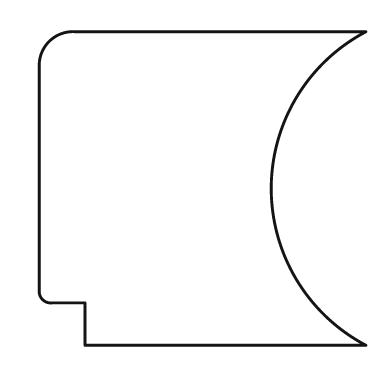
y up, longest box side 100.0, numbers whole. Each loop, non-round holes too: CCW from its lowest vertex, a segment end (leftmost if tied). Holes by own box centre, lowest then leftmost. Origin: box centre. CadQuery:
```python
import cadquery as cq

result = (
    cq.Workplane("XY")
    .moveTo(-36.0, -48.0)
    .lineTo(50.0, -48.0)
    .threePointArc((21.0, 0.0), (50.0, 48.0))
    .lineTo(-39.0, 48.0)
    .threePointArc((-47.0, 45.0), (-50.0, 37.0))
    .lineTo(-50.0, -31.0)
    .threePointArc((-49.0, -34.0), (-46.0, -35.0))
    .lineTo(-36.0, -35.0)
    .close()
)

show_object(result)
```